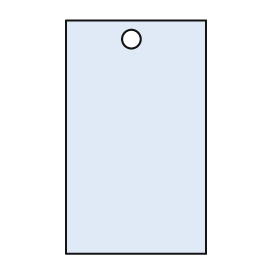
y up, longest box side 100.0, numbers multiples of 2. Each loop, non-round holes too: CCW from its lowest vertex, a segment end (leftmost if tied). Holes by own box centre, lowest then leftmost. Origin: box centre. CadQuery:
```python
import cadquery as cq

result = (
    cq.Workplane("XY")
    .moveTo(-30.0, -50.0)
    .lineTo(30.0, -50.0)
    .lineTo(30.0, 50.0)
    .lineTo(-30.0, 50.0)
    .close()
    .moveTo(-2.0, 42.0)
    .circle(4.0)
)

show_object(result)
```